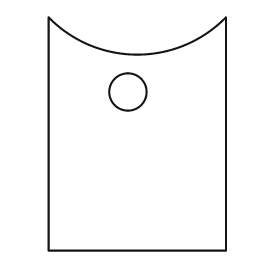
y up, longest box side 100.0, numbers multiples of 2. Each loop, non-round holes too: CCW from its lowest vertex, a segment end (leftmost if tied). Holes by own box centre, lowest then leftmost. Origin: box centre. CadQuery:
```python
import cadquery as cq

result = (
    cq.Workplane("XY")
    .moveTo(-38.0, -50.0)
    .lineTo(38.0, -50.0)
    .lineTo(38.0, 50.0)
    .threePointArc((0.0, 34.0), (-38.0, 50.0))
    .close()
    .moveTo(-4.0, 18.0)
    .circle(8.0)
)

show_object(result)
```